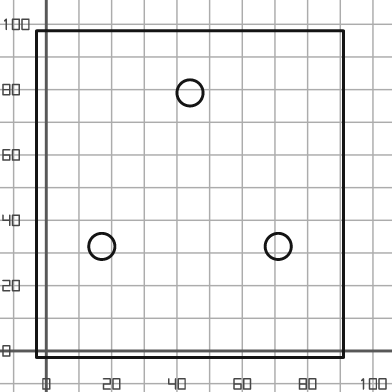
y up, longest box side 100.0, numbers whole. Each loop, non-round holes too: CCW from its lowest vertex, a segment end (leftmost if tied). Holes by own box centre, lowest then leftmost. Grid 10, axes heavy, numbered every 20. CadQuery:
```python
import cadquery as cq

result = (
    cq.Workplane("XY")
    .moveTo(-3.0, -2.0)
    .lineTo(91.0, -2.0)
    .lineTo(91.0, 98.0)
    .lineTo(-3.0, 98.0)
    .close()
    .moveTo(17.0, 32.0)
    .circle(4.0)
    .moveTo(71.0, 32.0)
    .circle(4.0)
    .moveTo(44.0, 79.0)
    .circle(4.0)
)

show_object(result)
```